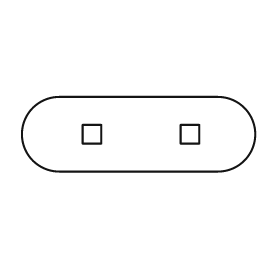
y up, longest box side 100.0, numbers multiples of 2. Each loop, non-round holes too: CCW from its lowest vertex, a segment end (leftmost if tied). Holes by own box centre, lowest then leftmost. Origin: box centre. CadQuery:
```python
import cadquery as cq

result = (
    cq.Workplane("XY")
    .moveTo(-34.0, -16.0)
    .lineTo(34.0, -16.0)
    .threePointArc((50.0, 0.0), (34.0, 16.0))
    .lineTo(-34.0, 16.0)
    .threePointArc((-50.0, 0.0), (-34.0, -16.0))
    .close()
    .moveTo(-24.0, -4.0)
    .lineTo(-16.0, -4.0)
    .lineTo(-16.0, 4.0)
    .lineTo(-24.0, 4.0)
    .close()
    .moveTo(18.0, -4.0)
    .lineTo(26.0, -4.0)
    .lineTo(26.0, 4.0)
    .lineTo(18.0, 4.0)
    .close()
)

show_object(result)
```